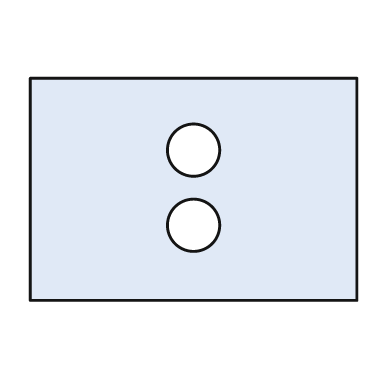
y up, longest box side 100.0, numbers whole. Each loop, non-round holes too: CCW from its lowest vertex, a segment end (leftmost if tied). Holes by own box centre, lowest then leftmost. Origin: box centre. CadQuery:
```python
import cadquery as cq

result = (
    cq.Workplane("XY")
    .moveTo(-50.0, -34.0)
    .lineTo(50.0, -34.0)
    .lineTo(50.0, 34.0)
    .lineTo(-50.0, 34.0)
    .close()
    .moveTo(0.0, -11.0)
    .circle(8.0)
    .moveTo(0.0, 12.0)
    .circle(8.0)
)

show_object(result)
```